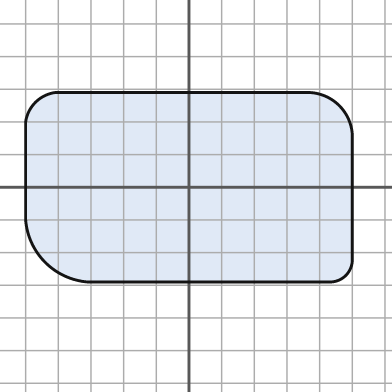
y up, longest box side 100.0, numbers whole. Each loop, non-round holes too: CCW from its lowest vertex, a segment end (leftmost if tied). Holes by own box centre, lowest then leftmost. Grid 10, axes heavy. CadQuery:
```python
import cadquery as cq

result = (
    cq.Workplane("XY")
    .moveTo(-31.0, -29.0)
    .lineTo(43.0, -29.0)
    .threePointArc((48.0, -27.0), (50.0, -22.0))
    .lineTo(50.0, 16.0)
    .threePointArc((46.0, 25.0), (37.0, 29.0))
    .lineTo(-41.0, 29.0)
    .threePointArc((-47.0, 26.0), (-50.0, 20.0))
    .lineTo(-50.0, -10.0)
    .threePointArc((-44.0, -23.0), (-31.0, -29.0))
    .close()
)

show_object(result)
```